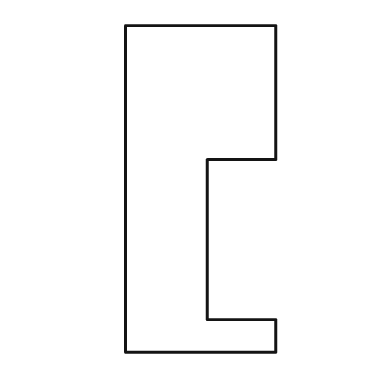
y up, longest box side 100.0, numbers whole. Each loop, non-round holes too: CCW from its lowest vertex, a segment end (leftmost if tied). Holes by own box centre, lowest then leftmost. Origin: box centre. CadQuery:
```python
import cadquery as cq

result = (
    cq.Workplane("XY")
    .moveTo(-23.0, -50.0)
    .lineTo(23.0, -50.0)
    .lineTo(23.0, -40.0)
    .lineTo(2.0, -40.0)
    .lineTo(2.0, 9.0)
    .lineTo(23.0, 9.0)
    .lineTo(23.0, 50.0)
    .lineTo(-23.0, 50.0)
    .close()
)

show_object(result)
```